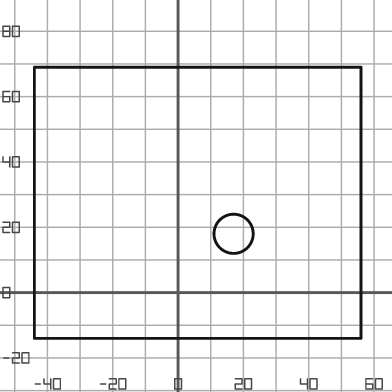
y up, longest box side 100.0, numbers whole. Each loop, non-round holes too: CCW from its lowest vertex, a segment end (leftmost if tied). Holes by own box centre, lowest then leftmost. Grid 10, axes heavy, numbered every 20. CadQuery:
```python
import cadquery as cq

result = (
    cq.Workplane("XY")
    .moveTo(-44.0, -14.0)
    .lineTo(56.0, -14.0)
    .lineTo(56.0, 69.0)
    .lineTo(-44.0, 69.0)
    .close()
    .moveTo(17.0, 18.0)
    .circle(6.0)
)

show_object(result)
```